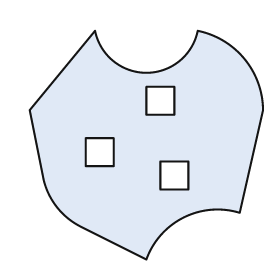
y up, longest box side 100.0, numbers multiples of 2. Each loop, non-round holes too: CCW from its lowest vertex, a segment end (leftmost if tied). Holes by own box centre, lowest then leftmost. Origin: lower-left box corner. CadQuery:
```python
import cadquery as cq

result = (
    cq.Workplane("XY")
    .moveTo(50.0, 0.0)
    .threePointArc((66.0, 18.0), (90.0, 20.0))
    .lineTo(100.0, 64.0)
    .threePointArc((92.0, 86.0), (72.0, 98.0))
    .threePointArc((50.0, 80.0), (28.0, 98.0))
    .lineTo(0.0, 64.0)
    .lineTo(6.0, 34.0)
    .threePointArc((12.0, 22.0), (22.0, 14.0))
    .close()
    .moveTo(56.0, 30.0)
    .lineTo(68.0, 30.0)
    .lineTo(68.0, 42.0)
    .lineTo(56.0, 42.0)
    .close()
    .moveTo(24.0, 40.0)
    .lineTo(36.0, 40.0)
    .lineTo(36.0, 52.0)
    .lineTo(24.0, 52.0)
    .close()
    .moveTo(50.0, 62.0)
    .lineTo(62.0, 62.0)
    .lineTo(62.0, 74.0)
    .lineTo(50.0, 74.0)
    .close()
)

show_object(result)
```